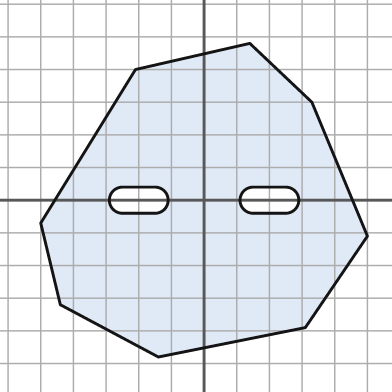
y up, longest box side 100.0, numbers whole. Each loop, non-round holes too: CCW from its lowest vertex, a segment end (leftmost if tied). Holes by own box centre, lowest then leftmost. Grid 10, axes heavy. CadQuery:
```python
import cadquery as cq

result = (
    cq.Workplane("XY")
    .moveTo(-14.0, -48.0)
    .lineTo(31.0, -39.0)
    .lineTo(50.0, -11.0)
    .lineTo(33.0, 30.0)
    .lineTo(14.0, 48.0)
    .lineTo(-21.0, 40.0)
    .lineTo(-50.0, -7.0)
    .lineTo(-44.0, -32.0)
    .close()
    .moveTo(-25.0, -4.0)
    .lineTo(-15.0, -4.0)
    .threePointArc((-11.0, 0.0), (-15.0, 4.0))
    .lineTo(-25.0, 4.0)
    .threePointArc((-29.0, 0.0), (-25.0, -4.0))
    .close()
    .moveTo(15.0, -4.0)
    .lineTo(25.0, -4.0)
    .threePointArc((29.0, 0.0), (25.0, 4.0))
    .lineTo(15.0, 4.0)
    .threePointArc((11.0, 0.0), (15.0, -4.0))
    .close()
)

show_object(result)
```